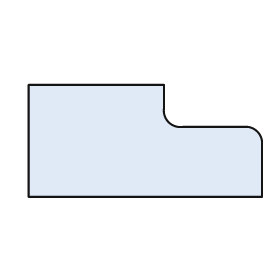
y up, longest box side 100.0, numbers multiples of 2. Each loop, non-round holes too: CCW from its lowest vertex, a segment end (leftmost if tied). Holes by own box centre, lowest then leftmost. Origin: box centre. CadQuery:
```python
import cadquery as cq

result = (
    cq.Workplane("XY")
    .moveTo(-50.0, -24.0)
    .lineTo(50.0, -24.0)
    .lineTo(50.0, 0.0)
    .threePointArc((48.0, 4.0), (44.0, 6.0))
    .lineTo(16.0, 6.0)
    .threePointArc((10.0, 8.0), (8.0, 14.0))
    .lineTo(8.0, 24.0)
    .lineTo(-50.0, 24.0)
    .close()
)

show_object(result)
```